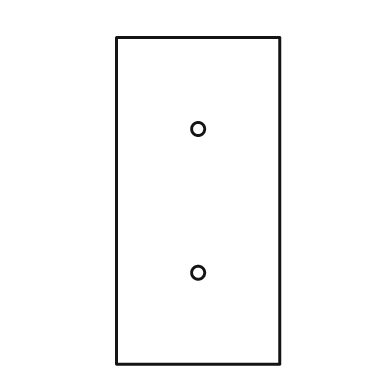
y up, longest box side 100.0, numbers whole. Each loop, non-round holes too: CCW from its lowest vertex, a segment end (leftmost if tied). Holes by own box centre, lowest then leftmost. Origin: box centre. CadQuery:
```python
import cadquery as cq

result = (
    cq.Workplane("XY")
    .moveTo(-25.0, -50.0)
    .lineTo(25.0, -50.0)
    .lineTo(25.0, 50.0)
    .lineTo(-25.0, 50.0)
    .close()
    .moveTo(0.0, -22.0)
    .circle(2.0)
    .moveTo(0.0, 22.0)
    .circle(2.0)
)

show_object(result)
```